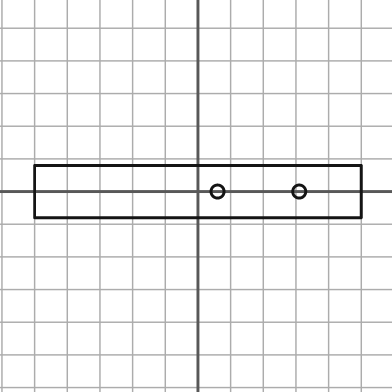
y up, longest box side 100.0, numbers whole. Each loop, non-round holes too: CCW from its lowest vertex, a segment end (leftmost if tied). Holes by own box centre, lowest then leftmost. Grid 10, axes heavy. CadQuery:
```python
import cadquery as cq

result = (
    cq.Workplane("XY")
    .moveTo(-50.0, -8.0)
    .lineTo(50.0, -8.0)
    .lineTo(50.0, 8.0)
    .lineTo(-50.0, 8.0)
    .close()
    .moveTo(6.0, 0.0)
    .circle(2.0)
    .moveTo(31.0, 0.0)
    .circle(2.0)
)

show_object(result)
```